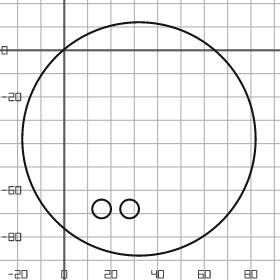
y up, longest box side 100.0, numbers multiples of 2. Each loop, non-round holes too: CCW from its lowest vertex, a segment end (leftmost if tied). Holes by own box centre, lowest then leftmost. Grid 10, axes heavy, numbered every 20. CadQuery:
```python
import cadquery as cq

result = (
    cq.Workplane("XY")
    .moveTo(32.0, -38.0)
    .circle(50.0)
    .moveTo(16.0, -68.0)
    .circle(4.0)
    .moveTo(28.0, -68.0)
    .circle(4.0)
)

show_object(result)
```